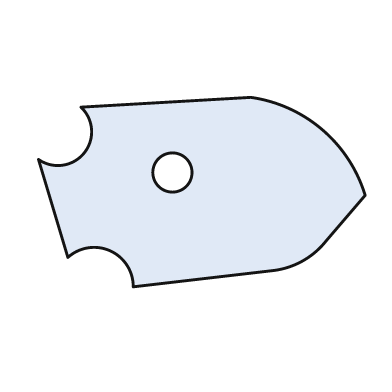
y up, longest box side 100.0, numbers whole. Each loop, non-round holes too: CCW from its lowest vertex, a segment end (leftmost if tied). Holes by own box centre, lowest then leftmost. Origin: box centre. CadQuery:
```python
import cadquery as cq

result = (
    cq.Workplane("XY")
    .moveTo(-21.0, -29.0)
    .lineTo(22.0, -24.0)
    .threePointArc((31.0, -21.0), (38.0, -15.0))
    .lineTo(50.0, -1.0)
    .threePointArc((37.0, 19.0), (15.0, 29.0))
    .lineTo(-37.0, 26.0)
    .threePointArc((-36.0, 12.0), (-50.0, 10.0))
    .lineTo(-41.0, -20.0)
    .threePointArc((-28.0, -18.0), (-21.0, -29.0))
    .close()
    .moveTo(-9.0, 6.0)
    .circle(6.0)
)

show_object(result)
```